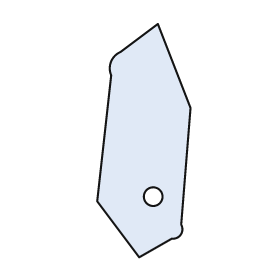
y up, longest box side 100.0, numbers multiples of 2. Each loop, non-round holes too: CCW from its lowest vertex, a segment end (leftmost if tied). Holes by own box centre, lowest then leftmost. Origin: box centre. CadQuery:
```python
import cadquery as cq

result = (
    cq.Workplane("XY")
    .moveTo(-2.0, -50.0)
    .lineTo(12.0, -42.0)
    .threePointArc((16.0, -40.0), (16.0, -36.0))
    .lineTo(20.0, 14.0)
    .lineTo(6.0, 50.0)
    .lineTo(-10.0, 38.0)
    .threePointArc((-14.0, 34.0), (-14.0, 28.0))
    .lineTo(-20.0, -26.0)
    .close()
    .moveTo(4.0, -24.0)
    .circle(4.0)
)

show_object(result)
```